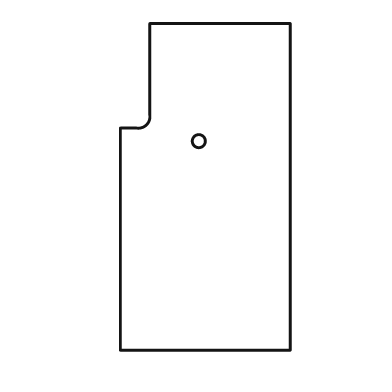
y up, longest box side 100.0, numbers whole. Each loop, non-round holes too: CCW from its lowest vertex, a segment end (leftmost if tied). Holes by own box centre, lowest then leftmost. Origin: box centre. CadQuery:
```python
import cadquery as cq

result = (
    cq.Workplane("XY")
    .moveTo(-26.0, -50.0)
    .lineTo(26.0, -50.0)
    .lineTo(26.0, 50.0)
    .lineTo(-17.0, 50.0)
    .lineTo(-17.0, 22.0)
    .threePointArc((-18.0, 19.0), (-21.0, 18.0))
    .lineTo(-26.0, 18.0)
    .close()
    .moveTo(-2.0, 14.0)
    .circle(2.0)
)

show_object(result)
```